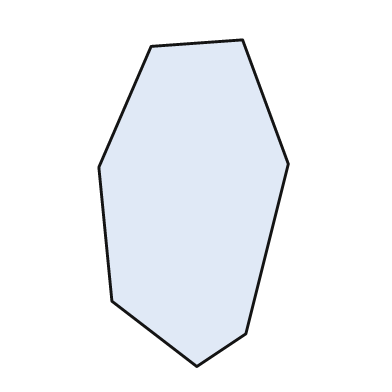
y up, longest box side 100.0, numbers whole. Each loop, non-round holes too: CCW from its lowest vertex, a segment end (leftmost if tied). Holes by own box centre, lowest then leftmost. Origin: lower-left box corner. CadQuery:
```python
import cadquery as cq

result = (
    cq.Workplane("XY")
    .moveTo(30.0, 0.0)
    .lineTo(45.0, 10.0)
    .lineTo(58.0, 62.0)
    .lineTo(44.0, 100.0)
    .lineTo(16.0, 98.0)
    .lineTo(0.0, 61.0)
    .lineTo(4.0, 20.0)
    .close()
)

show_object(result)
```